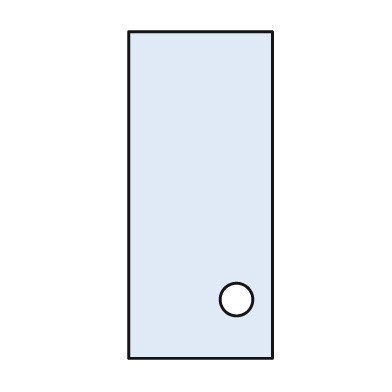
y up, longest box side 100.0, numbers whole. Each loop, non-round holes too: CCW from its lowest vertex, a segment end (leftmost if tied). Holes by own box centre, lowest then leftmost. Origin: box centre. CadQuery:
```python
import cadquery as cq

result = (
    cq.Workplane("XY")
    .moveTo(-22.0, -50.0)
    .lineTo(22.0, -50.0)
    .lineTo(22.0, 50.0)
    .lineTo(-22.0, 50.0)
    .close()
    .moveTo(11.0, -32.0)
    .circle(5.0)
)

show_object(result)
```